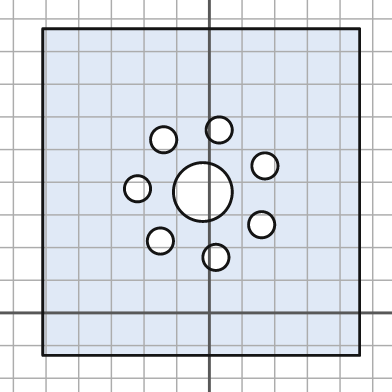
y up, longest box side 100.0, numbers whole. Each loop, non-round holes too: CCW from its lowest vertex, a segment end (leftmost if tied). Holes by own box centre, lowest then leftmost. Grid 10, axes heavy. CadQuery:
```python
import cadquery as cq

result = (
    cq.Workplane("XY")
    .moveTo(-51.0, -13.0)
    .lineTo(46.0, -13.0)
    .lineTo(46.0, 87.0)
    .lineTo(-51.0, 87.0)
    .close()
    .moveTo(2.0, 17.0)
    .circle(4.0)
    .moveTo(-15.0, 22.0)
    .circle(4.0)
    .moveTo(16.0, 27.0)
    .circle(4.0)
    .moveTo(-2.0, 37.0)
    .circle(9.0)
    .moveTo(-22.0, 38.0)
    .circle(4.0)
    .moveTo(17.0, 45.0)
    .circle(4.0)
    .moveTo(-14.0, 53.0)
    .circle(4.0)
    .moveTo(3.0, 56.0)
    .circle(4.0)
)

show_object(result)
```